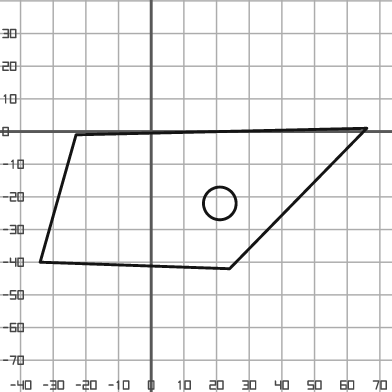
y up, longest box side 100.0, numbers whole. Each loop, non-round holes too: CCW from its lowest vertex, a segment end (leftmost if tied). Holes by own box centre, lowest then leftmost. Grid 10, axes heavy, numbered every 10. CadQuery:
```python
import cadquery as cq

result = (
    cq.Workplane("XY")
    .moveTo(24.0, -42.0)
    .lineTo(66.0, 1.0)
    .lineTo(-23.0, -1.0)
    .lineTo(-34.0, -40.0)
    .close()
    .moveTo(21.0, -22.0)
    .circle(5.0)
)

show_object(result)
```